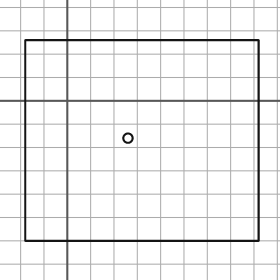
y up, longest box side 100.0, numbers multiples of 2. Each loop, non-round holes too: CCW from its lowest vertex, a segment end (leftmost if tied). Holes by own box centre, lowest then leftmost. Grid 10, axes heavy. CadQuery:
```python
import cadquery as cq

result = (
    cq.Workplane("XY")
    .moveTo(-18.0, -60.0)
    .lineTo(82.0, -60.0)
    .lineTo(82.0, 26.0)
    .lineTo(-18.0, 26.0)
    .close()
    .moveTo(26.0, -16.0)
    .circle(2.0)
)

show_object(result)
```